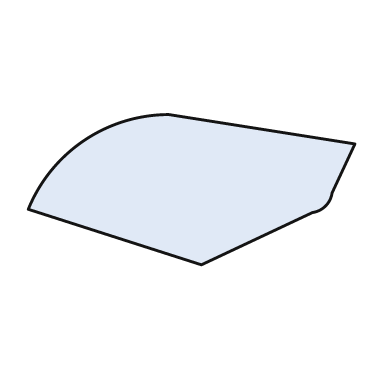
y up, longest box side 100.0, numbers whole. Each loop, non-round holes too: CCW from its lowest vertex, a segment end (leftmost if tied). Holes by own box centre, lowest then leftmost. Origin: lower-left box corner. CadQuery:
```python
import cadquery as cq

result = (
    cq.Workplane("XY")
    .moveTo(53.0, 0.0)
    .lineTo(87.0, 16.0)
    .threePointArc((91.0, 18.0), (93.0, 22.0))
    .lineTo(100.0, 37.0)
    .lineTo(43.0, 46.0)
    .threePointArc((17.0, 38.0), (0.0, 17.0))
    .close()
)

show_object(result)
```